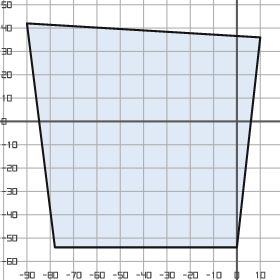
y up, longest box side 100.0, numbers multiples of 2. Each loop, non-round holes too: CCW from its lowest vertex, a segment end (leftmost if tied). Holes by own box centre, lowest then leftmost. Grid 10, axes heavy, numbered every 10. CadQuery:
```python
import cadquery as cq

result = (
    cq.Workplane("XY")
    .moveTo(-78.0, -54.0)
    .lineTo(0.0, -54.0)
    .lineTo(10.0, 36.0)
    .lineTo(-90.0, 42.0)
    .close()
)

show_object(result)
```